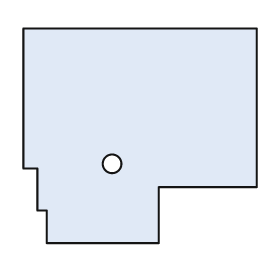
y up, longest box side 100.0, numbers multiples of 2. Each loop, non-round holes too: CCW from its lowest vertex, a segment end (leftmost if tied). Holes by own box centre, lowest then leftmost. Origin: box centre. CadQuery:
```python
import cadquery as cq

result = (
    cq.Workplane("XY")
    .moveTo(-40.0, -46.0)
    .lineTo(8.0, -46.0)
    .lineTo(8.0, -22.0)
    .lineTo(50.0, -22.0)
    .lineTo(50.0, 46.0)
    .lineTo(-50.0, 46.0)
    .lineTo(-50.0, -14.0)
    .lineTo(-44.0, -14.0)
    .lineTo(-44.0, -32.0)
    .lineTo(-40.0, -32.0)
    .close()
    .moveTo(-12.0, -12.0)
    .circle(4.0)
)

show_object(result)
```